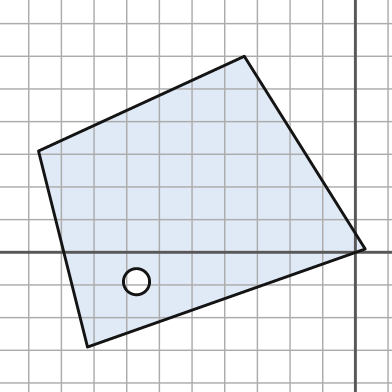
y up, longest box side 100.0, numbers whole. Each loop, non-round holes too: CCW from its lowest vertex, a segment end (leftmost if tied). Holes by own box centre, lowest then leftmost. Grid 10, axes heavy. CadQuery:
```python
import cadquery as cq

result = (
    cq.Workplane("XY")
    .moveTo(-82.0, -29.0)
    .lineTo(3.0, 1.0)
    .lineTo(-34.0, 60.0)
    .lineTo(-97.0, 31.0)
    .close()
    .moveTo(-67.0, -9.0)
    .circle(4.0)
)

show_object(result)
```